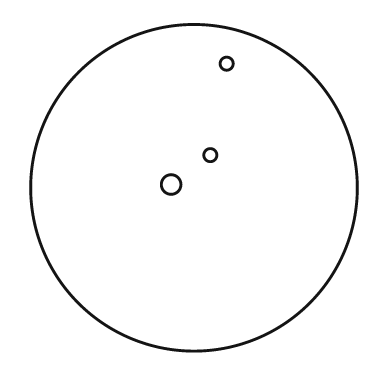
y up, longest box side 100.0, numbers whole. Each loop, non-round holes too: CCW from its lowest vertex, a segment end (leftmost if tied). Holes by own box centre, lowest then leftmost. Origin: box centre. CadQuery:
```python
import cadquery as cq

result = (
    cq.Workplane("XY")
    .moveTo(0.0, 0.0)
    .circle(50.0)
    .moveTo(-7.0, 1.0)
    .circle(3.0)
    .moveTo(5.0, 10.0)
    .circle(2.0)
    .moveTo(10.0, 38.0)
    .circle(2.0)
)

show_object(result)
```